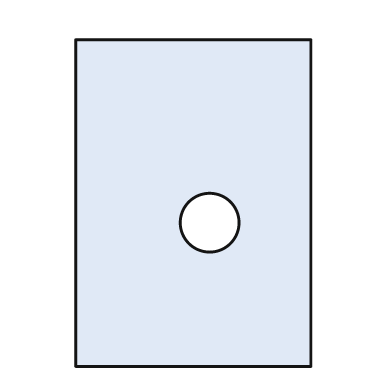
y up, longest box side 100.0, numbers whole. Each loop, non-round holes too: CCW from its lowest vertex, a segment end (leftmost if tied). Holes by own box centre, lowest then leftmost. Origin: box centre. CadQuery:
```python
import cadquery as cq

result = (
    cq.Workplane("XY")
    .moveTo(-36.0, -50.0)
    .lineTo(36.0, -50.0)
    .lineTo(36.0, 50.0)
    .lineTo(-36.0, 50.0)
    .close()
    .moveTo(5.0, -6.0)
    .circle(9.0)
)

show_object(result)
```